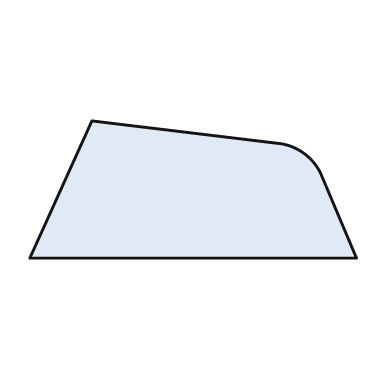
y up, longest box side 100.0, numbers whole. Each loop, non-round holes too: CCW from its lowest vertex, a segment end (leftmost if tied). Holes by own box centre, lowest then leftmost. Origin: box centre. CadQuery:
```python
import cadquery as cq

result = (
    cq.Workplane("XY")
    .moveTo(-50.0, -21.0)
    .lineTo(50.0, -21.0)
    .lineTo(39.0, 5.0)
    .threePointArc((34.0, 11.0), (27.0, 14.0))
    .lineTo(-31.0, 21.0)
    .close()
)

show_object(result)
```